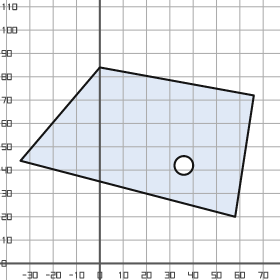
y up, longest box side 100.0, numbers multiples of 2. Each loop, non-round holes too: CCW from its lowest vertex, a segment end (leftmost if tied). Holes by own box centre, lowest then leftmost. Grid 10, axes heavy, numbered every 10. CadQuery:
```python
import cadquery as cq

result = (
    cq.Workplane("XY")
    .moveTo(58.0, 20.0)
    .lineTo(66.0, 72.0)
    .lineTo(0.0, 84.0)
    .lineTo(-34.0, 44.0)
    .close()
    .moveTo(36.0, 42.0)
    .circle(4.0)
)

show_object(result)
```